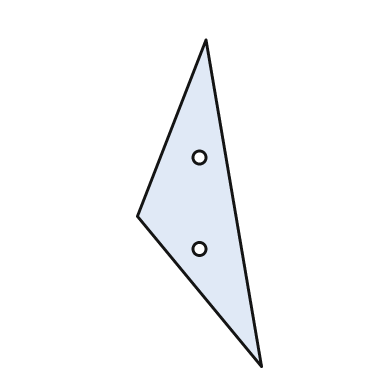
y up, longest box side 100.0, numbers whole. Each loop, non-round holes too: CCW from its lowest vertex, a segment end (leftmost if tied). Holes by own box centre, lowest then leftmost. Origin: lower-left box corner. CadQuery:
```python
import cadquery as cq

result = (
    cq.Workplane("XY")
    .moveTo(38.0, 0.0)
    .lineTo(21.0, 100.0)
    .lineTo(0.0, 46.0)
    .close()
    .moveTo(19.0, 36.0)
    .circle(2.0)
    .moveTo(19.0, 64.0)
    .circle(2.0)
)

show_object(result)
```